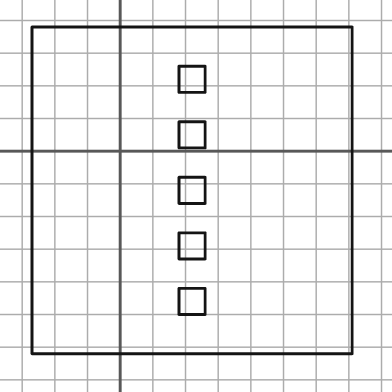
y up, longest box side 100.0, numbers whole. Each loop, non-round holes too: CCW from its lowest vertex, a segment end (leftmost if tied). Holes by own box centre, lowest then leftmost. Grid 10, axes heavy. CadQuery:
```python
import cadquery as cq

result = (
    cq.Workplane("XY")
    .moveTo(-27.0, -62.0)
    .lineTo(71.0, -62.0)
    .lineTo(71.0, 38.0)
    .lineTo(-27.0, 38.0)
    .close()
    .moveTo(18.0, -50.0)
    .lineTo(26.0, -50.0)
    .lineTo(26.0, -42.0)
    .lineTo(18.0, -42.0)
    .close()
    .moveTo(18.0, -33.0)
    .lineTo(26.0, -33.0)
    .lineTo(26.0, -25.0)
    .lineTo(18.0, -25.0)
    .close()
    .moveTo(18.0, -16.0)
    .lineTo(26.0, -16.0)
    .lineTo(26.0, -8.0)
    .lineTo(18.0, -8.0)
    .close()
    .moveTo(18.0, 1.0)
    .lineTo(26.0, 1.0)
    .lineTo(26.0, 9.0)
    .lineTo(18.0, 9.0)
    .close()
    .moveTo(18.0, 18.0)
    .lineTo(26.0, 18.0)
    .lineTo(26.0, 26.0)
    .lineTo(18.0, 26.0)
    .close()
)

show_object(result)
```